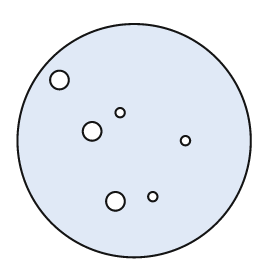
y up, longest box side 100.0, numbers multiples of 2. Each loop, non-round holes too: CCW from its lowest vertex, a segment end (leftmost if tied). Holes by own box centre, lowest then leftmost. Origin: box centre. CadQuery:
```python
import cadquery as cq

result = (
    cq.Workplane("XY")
    .moveTo(0.0, 0.0)
    .circle(50.0)
    .moveTo(-8.0, -26.0)
    .circle(4.0)
    .moveTo(8.0, -24.0)
    .circle(2.0)
    .moveTo(22.0, 0.0)
    .circle(2.0)
    .moveTo(-18.0, 4.0)
    .circle(4.0)
    .moveTo(-6.0, 12.0)
    .circle(2.0)
    .moveTo(-32.0, 26.0)
    .circle(4.0)
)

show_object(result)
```